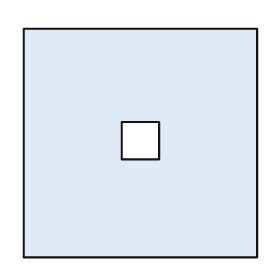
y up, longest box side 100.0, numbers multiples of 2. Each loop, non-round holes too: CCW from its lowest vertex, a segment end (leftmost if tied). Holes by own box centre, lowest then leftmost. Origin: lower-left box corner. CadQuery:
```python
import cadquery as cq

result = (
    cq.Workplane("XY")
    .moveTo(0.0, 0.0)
    .lineTo(100.0, 0.0)
    .lineTo(100.0, 98.0)
    .lineTo(0.0, 98.0)
    .close()
    .moveTo(42.0, 42.0)
    .lineTo(58.0, 42.0)
    .lineTo(58.0, 58.0)
    .lineTo(42.0, 58.0)
    .close()
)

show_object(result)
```